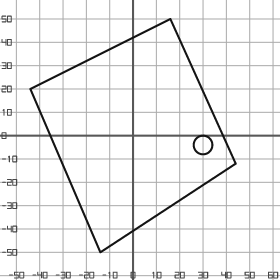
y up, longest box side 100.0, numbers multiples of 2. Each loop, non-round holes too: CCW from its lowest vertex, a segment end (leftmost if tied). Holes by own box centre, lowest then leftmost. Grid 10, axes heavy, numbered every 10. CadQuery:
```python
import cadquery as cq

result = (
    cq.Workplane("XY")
    .moveTo(-14.0, -50.0)
    .lineTo(44.0, -12.0)
    .lineTo(16.0, 50.0)
    .lineTo(-44.0, 20.0)
    .close()
    .moveTo(30.0, -4.0)
    .circle(4.0)
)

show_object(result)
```